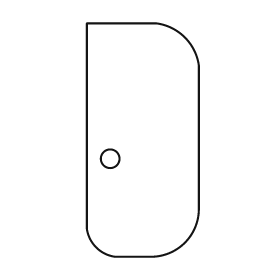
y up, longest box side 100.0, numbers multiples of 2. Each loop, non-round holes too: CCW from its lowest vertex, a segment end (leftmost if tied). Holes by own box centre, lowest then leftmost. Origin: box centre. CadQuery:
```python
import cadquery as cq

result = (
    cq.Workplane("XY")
    .moveTo(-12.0, -50.0)
    .lineTo(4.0, -50.0)
    .threePointArc((18.0, -44.0), (24.0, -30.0))
    .lineTo(24.0, 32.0)
    .threePointArc((18.0, 44.0), (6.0, 50.0))
    .lineTo(-24.0, 50.0)
    .lineTo(-24.0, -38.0)
    .threePointArc((-20.0, -46.0), (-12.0, -50.0))
    .close()
    .moveTo(-14.0, -8.0)
    .circle(4.0)
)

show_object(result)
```